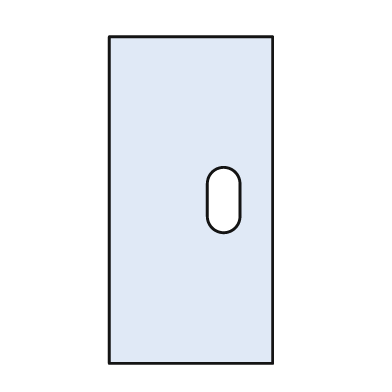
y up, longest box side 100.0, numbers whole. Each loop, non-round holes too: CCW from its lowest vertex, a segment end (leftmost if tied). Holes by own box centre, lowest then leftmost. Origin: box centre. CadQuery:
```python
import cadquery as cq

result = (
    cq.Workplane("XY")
    .moveTo(-25.0, -50.0)
    .lineTo(25.0, -50.0)
    .lineTo(25.0, 50.0)
    .lineTo(-25.0, 50.0)
    .close()
    .moveTo(5.0, -5.0)
    .threePointArc((10.0, -10.0), (15.0, -5.0))
    .lineTo(15.0, 5.0)
    .threePointArc((10.0, 10.0), (5.0, 5.0))
    .close()
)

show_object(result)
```